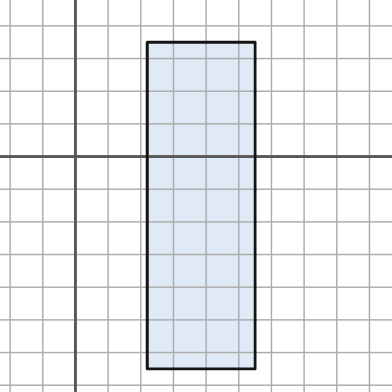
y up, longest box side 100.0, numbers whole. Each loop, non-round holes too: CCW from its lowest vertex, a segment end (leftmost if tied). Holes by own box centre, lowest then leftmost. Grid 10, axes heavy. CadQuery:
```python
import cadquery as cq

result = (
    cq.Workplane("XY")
    .moveTo(22.0, -65.0)
    .lineTo(55.0, -65.0)
    .lineTo(55.0, 35.0)
    .lineTo(22.0, 35.0)
    .close()
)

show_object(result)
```